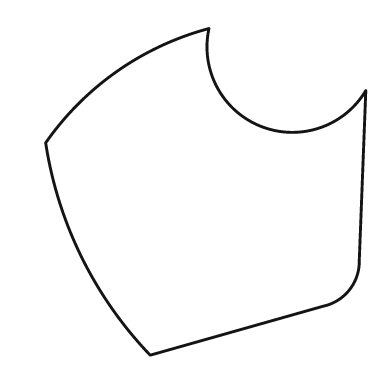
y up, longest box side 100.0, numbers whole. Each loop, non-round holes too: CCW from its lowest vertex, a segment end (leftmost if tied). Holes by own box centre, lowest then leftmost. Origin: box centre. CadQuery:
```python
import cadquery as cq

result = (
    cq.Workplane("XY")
    .moveTo(-17.0, -50.0)
    .lineTo(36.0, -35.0)
    .threePointArc((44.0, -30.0), (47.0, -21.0))
    .lineTo(49.0, 31.0)
    .threePointArc((17.0, 20.0), (1.0, 50.0))
    .threePointArc((-27.0, 37.0), (-49.0, 15.0))
    .threePointArc((-38.0, -20.0), (-17.0, -50.0))
    .close()
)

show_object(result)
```